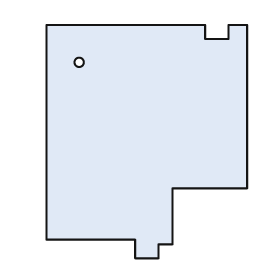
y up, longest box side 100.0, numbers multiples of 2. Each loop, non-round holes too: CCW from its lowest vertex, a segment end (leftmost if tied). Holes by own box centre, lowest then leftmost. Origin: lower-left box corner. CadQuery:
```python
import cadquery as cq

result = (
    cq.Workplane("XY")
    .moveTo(38.0, 0.0)
    .lineTo(48.0, 0.0)
    .lineTo(48.0, 6.0)
    .lineTo(54.0, 6.0)
    .lineTo(54.0, 30.0)
    .lineTo(86.0, 30.0)
    .lineTo(86.0, 100.0)
    .lineTo(78.0, 100.0)
    .lineTo(78.0, 94.0)
    .lineTo(68.0, 94.0)
    .lineTo(68.0, 100.0)
    .lineTo(0.0, 100.0)
    .lineTo(0.0, 8.0)
    .lineTo(38.0, 8.0)
    .close()
    .moveTo(14.0, 84.0)
    .circle(2.0)
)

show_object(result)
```